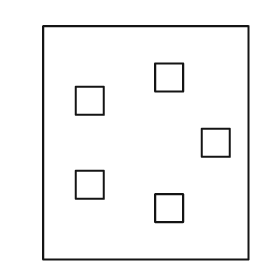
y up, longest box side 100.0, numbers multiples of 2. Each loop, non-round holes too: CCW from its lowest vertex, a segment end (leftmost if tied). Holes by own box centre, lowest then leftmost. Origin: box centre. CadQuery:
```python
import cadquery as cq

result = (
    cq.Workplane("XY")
    .moveTo(-44.0, -50.0)
    .lineTo(44.0, -50.0)
    .lineTo(44.0, 50.0)
    .lineTo(-44.0, 50.0)
    .close()
    .moveTo(4.0, -34.0)
    .lineTo(16.0, -34.0)
    .lineTo(16.0, -22.0)
    .lineTo(4.0, -22.0)
    .close()
    .moveTo(-30.0, -24.0)
    .lineTo(-18.0, -24.0)
    .lineTo(-18.0, -12.0)
    .lineTo(-30.0, -12.0)
    .close()
    .moveTo(24.0, -6.0)
    .lineTo(36.0, -6.0)
    .lineTo(36.0, 6.0)
    .lineTo(24.0, 6.0)
    .close()
    .moveTo(-30.0, 12.0)
    .lineTo(-18.0, 12.0)
    .lineTo(-18.0, 24.0)
    .lineTo(-30.0, 24.0)
    .close()
    .moveTo(4.0, 22.0)
    .lineTo(16.0, 22.0)
    .lineTo(16.0, 34.0)
    .lineTo(4.0, 34.0)
    .close()
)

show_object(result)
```